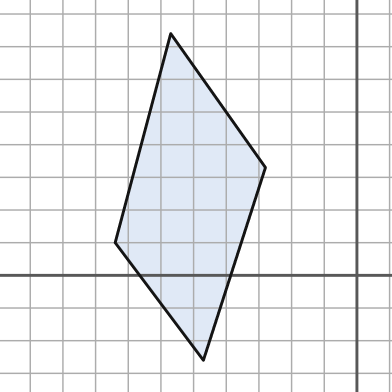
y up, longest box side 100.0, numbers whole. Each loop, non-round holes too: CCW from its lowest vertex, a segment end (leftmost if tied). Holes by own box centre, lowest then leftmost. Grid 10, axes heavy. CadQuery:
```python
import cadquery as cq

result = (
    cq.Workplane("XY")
    .moveTo(-47.0, -26.0)
    .lineTo(-28.0, 33.0)
    .lineTo(-57.0, 74.0)
    .lineTo(-74.0, 10.0)
    .close()
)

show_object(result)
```